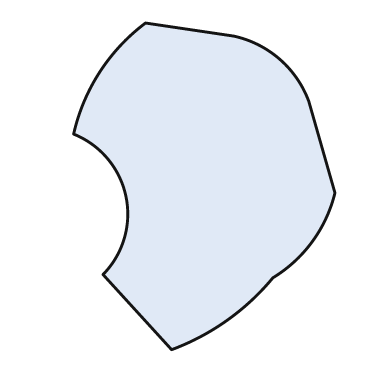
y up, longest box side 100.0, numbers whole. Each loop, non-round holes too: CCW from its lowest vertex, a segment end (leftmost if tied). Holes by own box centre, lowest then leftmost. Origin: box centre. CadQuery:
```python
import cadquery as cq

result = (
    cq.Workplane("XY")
    .moveTo(-10.0, -50.0)
    .threePointArc((7.0, -41.0), (21.0, -28.0))
    .threePointArc((33.0, -17.0), (40.0, -2.0))
    .lineTo(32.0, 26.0)
    .threePointArc((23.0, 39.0), (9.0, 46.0))
    .lineTo(-18.0, 50.0)
    .threePointArc((-32.0, 35.0), (-40.0, 16.0))
    .threePointArc((-24.0, -3.0), (-31.0, -27.0))
    .close()
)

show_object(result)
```